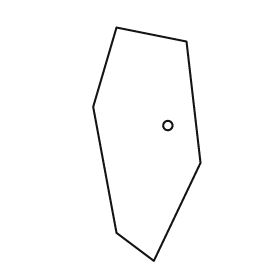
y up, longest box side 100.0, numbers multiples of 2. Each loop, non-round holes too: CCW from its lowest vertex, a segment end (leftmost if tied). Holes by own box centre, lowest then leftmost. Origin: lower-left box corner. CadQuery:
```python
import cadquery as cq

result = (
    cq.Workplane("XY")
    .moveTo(26.0, 0.0)
    .lineTo(46.0, 42.0)
    .lineTo(40.0, 94.0)
    .lineTo(10.0, 100.0)
    .lineTo(0.0, 66.0)
    .lineTo(10.0, 12.0)
    .close()
    .moveTo(32.0, 58.0)
    .circle(2.0)
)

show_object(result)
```